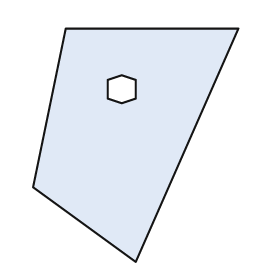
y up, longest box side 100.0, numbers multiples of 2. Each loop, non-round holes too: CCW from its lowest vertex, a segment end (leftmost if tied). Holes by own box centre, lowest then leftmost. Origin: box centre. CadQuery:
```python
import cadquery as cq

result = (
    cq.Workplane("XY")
    .moveTo(0.0, -50.0)
    .lineTo(44.0, 50.0)
    .lineTo(-30.0, 50.0)
    .lineTo(-44.0, -18.0)
    .close()
    .moveTo(-6.0, 18.0)
    .lineTo(0.0, 20.0)
    .lineTo(0.0, 28.0)
    .lineTo(-6.0, 30.0)
    .lineTo(-12.0, 28.0)
    .lineTo(-12.0, 20.0)
    .close()
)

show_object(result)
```